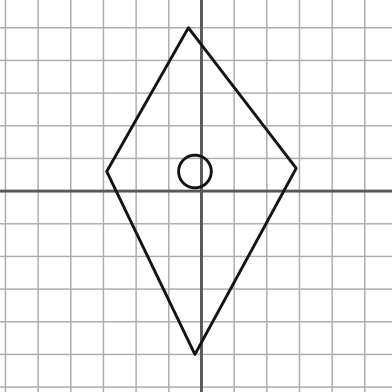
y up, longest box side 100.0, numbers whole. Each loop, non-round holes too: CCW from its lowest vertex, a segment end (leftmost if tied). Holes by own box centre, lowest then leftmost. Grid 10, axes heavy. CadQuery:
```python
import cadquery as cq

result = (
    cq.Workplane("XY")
    .moveTo(-2.0, -50.0)
    .lineTo(29.0, 7.0)
    .lineTo(-4.0, 50.0)
    .lineTo(-29.0, 6.0)
    .close()
    .moveTo(-2.0, 6.0)
    .circle(5.0)
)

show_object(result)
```